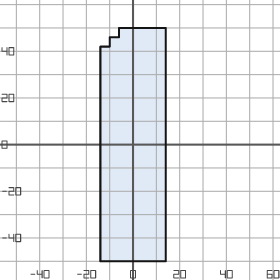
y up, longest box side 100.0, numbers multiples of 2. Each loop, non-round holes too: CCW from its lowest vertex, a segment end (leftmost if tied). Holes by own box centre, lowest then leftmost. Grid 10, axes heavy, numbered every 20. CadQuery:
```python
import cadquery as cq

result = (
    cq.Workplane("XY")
    .moveTo(-14.0, -50.0)
    .lineTo(14.0, -50.0)
    .lineTo(14.0, 50.0)
    .lineTo(-6.0, 50.0)
    .lineTo(-6.0, 46.0)
    .lineTo(-10.0, 46.0)
    .lineTo(-10.0, 42.0)
    .lineTo(-14.0, 42.0)
    .close()
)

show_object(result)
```